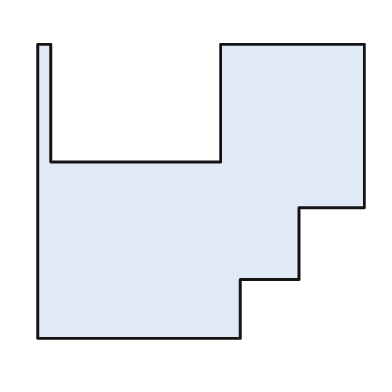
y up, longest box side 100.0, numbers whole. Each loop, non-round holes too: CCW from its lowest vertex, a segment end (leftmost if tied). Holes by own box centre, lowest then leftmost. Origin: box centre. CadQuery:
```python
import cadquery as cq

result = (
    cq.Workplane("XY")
    .moveTo(-50.0, -45.0)
    .lineTo(12.0, -45.0)
    .lineTo(12.0, -27.0)
    .lineTo(30.0, -27.0)
    .lineTo(30.0, -5.0)
    .lineTo(50.0, -5.0)
    .lineTo(50.0, 45.0)
    .lineTo(6.0, 45.0)
    .lineTo(6.0, 9.0)
    .lineTo(-46.0, 9.0)
    .lineTo(-46.0, 45.0)
    .lineTo(-50.0, 45.0)
    .close()
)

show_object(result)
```